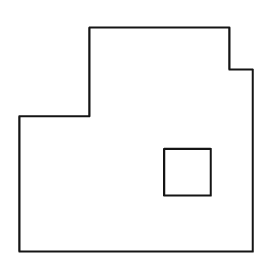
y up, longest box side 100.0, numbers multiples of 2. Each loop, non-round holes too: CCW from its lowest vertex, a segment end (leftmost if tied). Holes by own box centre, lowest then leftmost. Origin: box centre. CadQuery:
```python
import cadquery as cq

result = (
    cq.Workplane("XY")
    .moveTo(-50.0, -48.0)
    .lineTo(50.0, -48.0)
    .lineTo(50.0, 30.0)
    .lineTo(40.0, 30.0)
    .lineTo(40.0, 48.0)
    .lineTo(-20.0, 48.0)
    .lineTo(-20.0, 10.0)
    .lineTo(-50.0, 10.0)
    .close()
    .moveTo(12.0, -24.0)
    .lineTo(32.0, -24.0)
    .lineTo(32.0, -4.0)
    .lineTo(12.0, -4.0)
    .close()
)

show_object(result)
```